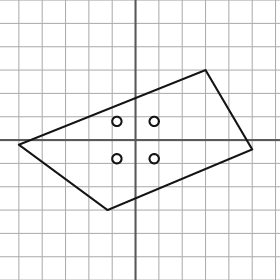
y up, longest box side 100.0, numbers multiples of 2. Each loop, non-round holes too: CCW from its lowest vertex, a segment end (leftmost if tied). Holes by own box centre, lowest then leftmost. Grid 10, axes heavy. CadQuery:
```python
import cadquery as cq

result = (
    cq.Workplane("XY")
    .moveTo(-12.0, -30.0)
    .lineTo(50.0, -4.0)
    .lineTo(30.0, 30.0)
    .lineTo(-50.0, -2.0)
    .close()
    .moveTo(-8.0, -8.0)
    .circle(2.0)
    .moveTo(8.0, -8.0)
    .circle(2.0)
    .moveTo(-8.0, 8.0)
    .circle(2.0)
    .moveTo(8.0, 8.0)
    .circle(2.0)
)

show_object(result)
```